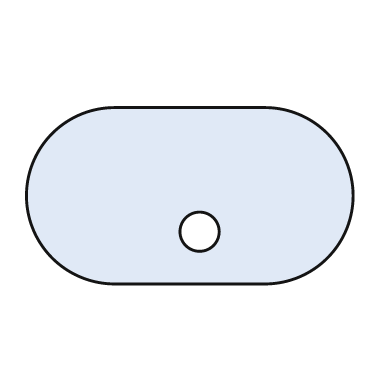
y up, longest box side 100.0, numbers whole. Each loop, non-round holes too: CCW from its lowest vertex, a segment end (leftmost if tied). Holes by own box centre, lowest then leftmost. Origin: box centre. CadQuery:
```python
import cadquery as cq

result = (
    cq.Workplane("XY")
    .moveTo(-23.0, -27.0)
    .lineTo(23.0, -27.0)
    .threePointArc((50.0, 0.0), (23.0, 27.0))
    .lineTo(-23.0, 27.0)
    .threePointArc((-50.0, 0.0), (-23.0, -27.0))
    .close()
    .moveTo(3.0, -11.0)
    .circle(6.0)
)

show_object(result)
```